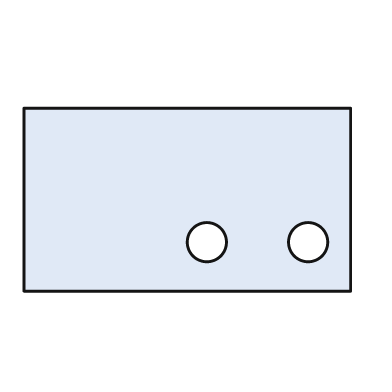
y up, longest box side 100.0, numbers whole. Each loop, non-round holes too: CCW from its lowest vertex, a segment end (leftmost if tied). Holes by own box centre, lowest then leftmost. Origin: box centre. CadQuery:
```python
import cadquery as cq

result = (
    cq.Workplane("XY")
    .moveTo(-50.0, -28.0)
    .lineTo(50.0, -28.0)
    .lineTo(50.0, 28.0)
    .lineTo(-50.0, 28.0)
    .close()
    .moveTo(6.0, -13.0)
    .circle(6.0)
    .moveTo(37.0, -13.0)
    .circle(6.0)
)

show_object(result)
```